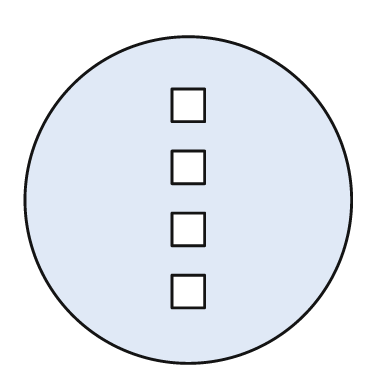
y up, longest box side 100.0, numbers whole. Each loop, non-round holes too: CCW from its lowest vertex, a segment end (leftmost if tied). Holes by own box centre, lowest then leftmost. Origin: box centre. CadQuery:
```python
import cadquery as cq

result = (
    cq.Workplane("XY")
    .moveTo(0.0, 0.0)
    .circle(50.0)
    .moveTo(-5.0, -33.0)
    .lineTo(5.0, -33.0)
    .lineTo(5.0, -23.0)
    .lineTo(-5.0, -23.0)
    .close()
    .moveTo(-5.0, -14.0)
    .lineTo(5.0, -14.0)
    .lineTo(5.0, -4.0)
    .lineTo(-5.0, -4.0)
    .close()
    .moveTo(-5.0, 5.0)
    .lineTo(5.0, 5.0)
    .lineTo(5.0, 15.0)
    .lineTo(-5.0, 15.0)
    .close()
    .moveTo(-5.0, 24.0)
    .lineTo(5.0, 24.0)
    .lineTo(5.0, 34.0)
    .lineTo(-5.0, 34.0)
    .close()
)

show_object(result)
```